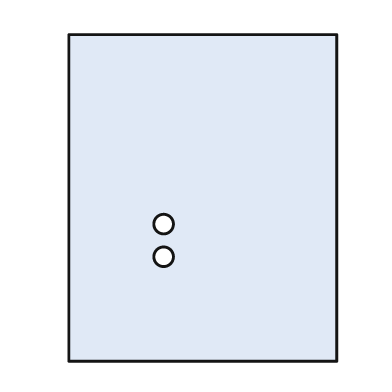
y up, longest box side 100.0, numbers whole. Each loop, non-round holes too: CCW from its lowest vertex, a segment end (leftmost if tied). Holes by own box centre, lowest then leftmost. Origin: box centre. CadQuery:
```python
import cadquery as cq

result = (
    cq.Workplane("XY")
    .moveTo(-41.0, -50.0)
    .lineTo(41.0, -50.0)
    .lineTo(41.0, 50.0)
    .lineTo(-41.0, 50.0)
    .close()
    .moveTo(-12.0, -18.0)
    .circle(3.0)
    .moveTo(-12.0, -8.0)
    .circle(3.0)
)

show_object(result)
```